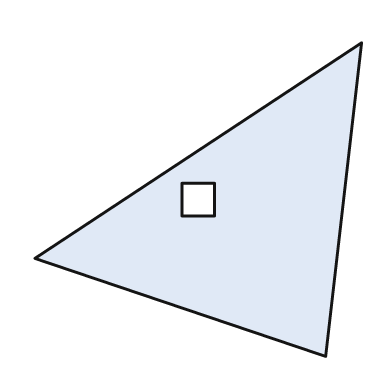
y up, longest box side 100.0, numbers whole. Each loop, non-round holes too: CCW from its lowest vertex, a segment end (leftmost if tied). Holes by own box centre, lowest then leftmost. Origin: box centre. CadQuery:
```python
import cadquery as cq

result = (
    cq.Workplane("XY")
    .moveTo(39.0, -48.0)
    .lineTo(50.0, 48.0)
    .lineTo(-50.0, -18.0)
    .close()
    .moveTo(-5.0, -5.0)
    .lineTo(5.0, -5.0)
    .lineTo(5.0, 5.0)
    .lineTo(-5.0, 5.0)
    .close()
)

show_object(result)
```